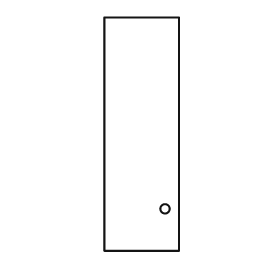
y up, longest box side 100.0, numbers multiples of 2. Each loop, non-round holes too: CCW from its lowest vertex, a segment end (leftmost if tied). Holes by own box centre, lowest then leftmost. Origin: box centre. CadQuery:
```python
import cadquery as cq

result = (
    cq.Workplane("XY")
    .moveTo(-16.0, -50.0)
    .lineTo(16.0, -50.0)
    .lineTo(16.0, 50.0)
    .lineTo(-16.0, 50.0)
    .close()
    .moveTo(10.0, -32.0)
    .circle(2.0)
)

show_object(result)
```